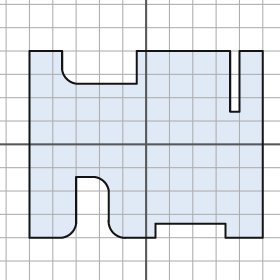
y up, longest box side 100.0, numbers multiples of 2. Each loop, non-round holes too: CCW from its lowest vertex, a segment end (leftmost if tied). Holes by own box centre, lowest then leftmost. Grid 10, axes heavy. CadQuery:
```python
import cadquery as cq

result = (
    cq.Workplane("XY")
    .moveTo(-50.0, -40.0)
    .lineTo(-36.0, -40.0)
    .threePointArc((-32.0, -38.0), (-30.0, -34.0))
    .lineTo(-30.0, -14.0)
    .lineTo(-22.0, -14.0)
    .threePointArc((-18.0, -16.0), (-16.0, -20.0))
    .lineTo(-16.0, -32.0)
    .threePointArc((-14.0, -38.0), (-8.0, -40.0))
    .lineTo(4.0, -40.0)
    .lineTo(4.0, -34.0)
    .lineTo(34.0, -34.0)
    .lineTo(34.0, -40.0)
    .lineTo(50.0, -40.0)
    .lineTo(50.0, 40.0)
    .lineTo(40.0, 40.0)
    .lineTo(40.0, 14.0)
    .lineTo(36.0, 14.0)
    .lineTo(36.0, 40.0)
    .lineTo(-4.0, 40.0)
    .lineTo(-4.0, 26.0)
    .lineTo(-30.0, 26.0)
    .threePointArc((-34.0, 28.0), (-36.0, 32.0))
    .lineTo(-36.0, 40.0)
    .lineTo(-50.0, 40.0)
    .close()
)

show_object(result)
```